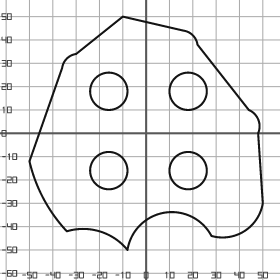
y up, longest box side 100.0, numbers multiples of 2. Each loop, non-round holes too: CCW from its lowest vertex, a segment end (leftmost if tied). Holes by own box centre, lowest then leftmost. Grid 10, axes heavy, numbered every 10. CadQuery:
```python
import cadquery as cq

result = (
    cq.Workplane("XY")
    .moveTo(-8.0, -50.0)
    .threePointArc((8.0, -34.0), (28.0, -44.0))
    .threePointArc((42.0, -42.0), (50.0, -30.0))
    .lineTo(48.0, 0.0)
    .threePointArc((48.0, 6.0), (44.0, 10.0))
    .lineTo(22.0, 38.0)
    .threePointArc((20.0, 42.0), (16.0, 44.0))
    .lineTo(-10.0, 50.0)
    .lineTo(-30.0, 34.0)
    .threePointArc((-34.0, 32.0), (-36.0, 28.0))
    .lineTo(-50.0, -12.0)
    .threePointArc((-44.0, -28.0), (-34.0, -42.0))
    .threePointArc((-20.0, -42.0), (-8.0, -50.0))
    .close()
    .moveTo(-16.0, -16.0)
    .circle(8.0)
    .moveTo(18.0, -16.0)
    .circle(8.0)
    .moveTo(-16.0, 18.0)
    .circle(8.0)
    .moveTo(18.0, 18.0)
    .circle(8.0)
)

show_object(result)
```